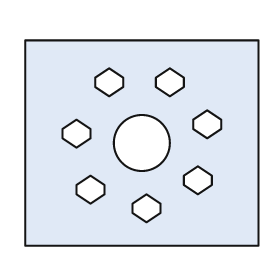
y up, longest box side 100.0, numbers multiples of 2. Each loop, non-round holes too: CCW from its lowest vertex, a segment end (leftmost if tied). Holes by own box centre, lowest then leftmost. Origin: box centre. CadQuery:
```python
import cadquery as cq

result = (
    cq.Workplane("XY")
    .moveTo(-50.0, -44.0)
    .lineTo(50.0, -44.0)
    .lineTo(50.0, 44.0)
    .lineTo(-50.0, 44.0)
    .close()
    .moveTo(2.0, -34.0)
    .lineTo(8.0, -30.0)
    .lineTo(8.0, -26.0)
    .lineTo(2.0, -22.0)
    .lineTo(-4.0, -26.0)
    .lineTo(-4.0, -30.0)
    .close()
    .moveTo(-22.0, -26.0)
    .lineTo(-16.0, -22.0)
    .lineTo(-16.0, -18.0)
    .lineTo(-22.0, -14.0)
    .lineTo(-28.0, -18.0)
    .lineTo(-28.0, -22.0)
    .close()
    .moveTo(24.0, -22.0)
    .lineTo(30.0, -18.0)
    .lineTo(30.0, -14.0)
    .lineTo(24.0, -10.0)
    .lineTo(18.0, -14.0)
    .lineTo(18.0, -18.0)
    .close()
    .moveTo(0.0, 0.0)
    .circle(12.0)
    .moveTo(-28.0, -2.0)
    .lineTo(-22.0, 2.0)
    .lineTo(-22.0, 6.0)
    .lineTo(-28.0, 10.0)
    .lineTo(-34.0, 6.0)
    .lineTo(-34.0, 2.0)
    .close()
    .moveTo(28.0, 2.0)
    .lineTo(34.0, 6.0)
    .lineTo(34.0, 10.0)
    .lineTo(28.0, 14.0)
    .lineTo(22.0, 10.0)
    .lineTo(22.0, 6.0)
    .close()
    .moveTo(-14.0, 20.0)
    .lineTo(-8.0, 24.0)
    .lineTo(-8.0, 28.0)
    .lineTo(-14.0, 32.0)
    .lineTo(-20.0, 28.0)
    .lineTo(-20.0, 24.0)
    .close()
    .moveTo(12.0, 20.0)
    .lineTo(18.0, 24.0)
    .lineTo(18.0, 28.0)
    .lineTo(12.0, 32.0)
    .lineTo(6.0, 28.0)
    .lineTo(6.0, 24.0)
    .close()
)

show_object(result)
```